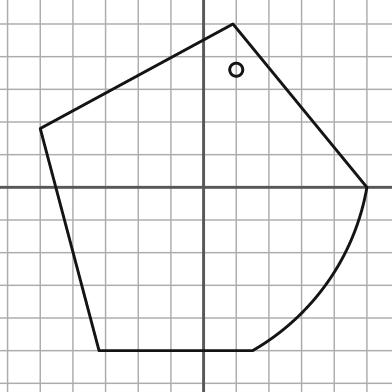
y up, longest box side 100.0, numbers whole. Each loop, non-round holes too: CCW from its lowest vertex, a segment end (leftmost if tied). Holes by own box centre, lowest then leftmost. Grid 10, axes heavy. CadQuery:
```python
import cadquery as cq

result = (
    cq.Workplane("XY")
    .moveTo(-32.0, -50.0)
    .lineTo(15.0, -50.0)
    .threePointArc((38.0, -29.0), (50.0, 0.0))
    .lineTo(9.0, 50.0)
    .lineTo(-50.0, 18.0)
    .close()
    .moveTo(10.0, 36.0)
    .circle(2.0)
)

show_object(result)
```